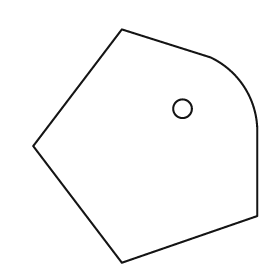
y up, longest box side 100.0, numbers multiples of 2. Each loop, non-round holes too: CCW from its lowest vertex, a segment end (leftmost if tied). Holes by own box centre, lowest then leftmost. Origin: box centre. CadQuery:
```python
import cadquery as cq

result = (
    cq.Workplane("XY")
    .moveTo(-10.0, -50.0)
    .lineTo(48.0, -30.0)
    .lineTo(48.0, 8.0)
    .threePointArc((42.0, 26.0), (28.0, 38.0))
    .lineTo(-10.0, 50.0)
    .lineTo(-48.0, 0.0)
    .close()
    .moveTo(16.0, 16.0)
    .circle(4.0)
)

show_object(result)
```